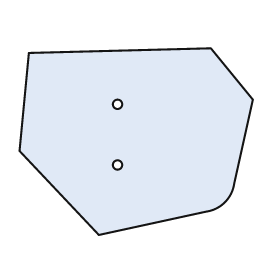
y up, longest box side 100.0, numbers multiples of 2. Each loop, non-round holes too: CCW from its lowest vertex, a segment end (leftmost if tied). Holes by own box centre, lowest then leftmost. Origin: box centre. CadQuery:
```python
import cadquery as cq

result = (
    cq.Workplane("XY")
    .moveTo(-16.0, -40.0)
    .lineTo(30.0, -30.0)
    .threePointArc((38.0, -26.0), (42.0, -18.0))
    .lineTo(50.0, 18.0)
    .lineTo(32.0, 40.0)
    .lineTo(-46.0, 38.0)
    .lineTo(-50.0, -4.0)
    .close()
    .moveTo(-8.0, -10.0)
    .circle(2.0)
    .moveTo(-8.0, 16.0)
    .circle(2.0)
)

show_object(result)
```